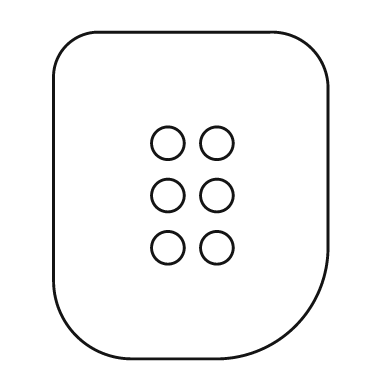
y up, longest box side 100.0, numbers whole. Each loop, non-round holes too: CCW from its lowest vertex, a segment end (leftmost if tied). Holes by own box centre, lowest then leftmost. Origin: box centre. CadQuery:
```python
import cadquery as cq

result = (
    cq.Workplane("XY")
    .moveTo(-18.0, -50.0)
    .lineTo(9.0, -50.0)
    .threePointArc((32.0, -40.0), (42.0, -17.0))
    .lineTo(42.0, 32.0)
    .threePointArc((37.0, 45.0), (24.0, 50.0))
    .lineTo(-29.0, 50.0)
    .threePointArc((-38.0, 46.0), (-42.0, 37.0))
    .lineTo(-42.0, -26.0)
    .threePointArc((-35.0, -43.0), (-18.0, -50.0))
    .close()
    .moveTo(-7.0, -16.0)
    .circle(5.0)
    .moveTo(8.0, -16.0)
    .circle(5.0)
    .moveTo(-7.0, 0.0)
    .circle(5.0)
    .moveTo(8.0, 0.0)
    .circle(5.0)
    .moveTo(-7.0, 16.0)
    .circle(5.0)
    .moveTo(8.0, 16.0)
    .circle(5.0)
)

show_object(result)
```